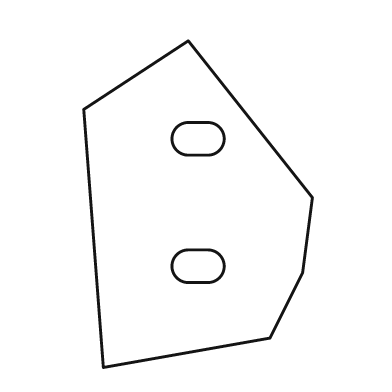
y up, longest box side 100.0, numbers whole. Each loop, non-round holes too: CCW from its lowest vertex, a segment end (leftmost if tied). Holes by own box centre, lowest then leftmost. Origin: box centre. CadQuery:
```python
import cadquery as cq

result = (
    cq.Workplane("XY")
    .moveTo(-29.0, -50.0)
    .lineTo(22.0, -41.0)
    .lineTo(32.0, -21.0)
    .lineTo(35.0, 2.0)
    .lineTo(-3.0, 50.0)
    .lineTo(-35.0, 29.0)
    .close()
    .moveTo(-3.0, -24.0)
    .lineTo(3.0, -24.0)
    .threePointArc((8.0, -19.0), (3.0, -14.0))
    .lineTo(-3.0, -14.0)
    .threePointArc((-8.0, -19.0), (-3.0, -24.0))
    .close()
    .moveTo(-3.0, 15.0)
    .lineTo(3.0, 15.0)
    .threePointArc((8.0, 20.0), (3.0, 25.0))
    .lineTo(-3.0, 25.0)
    .threePointArc((-8.0, 20.0), (-3.0, 15.0))
    .close()
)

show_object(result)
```